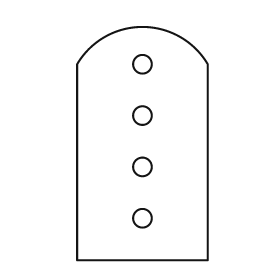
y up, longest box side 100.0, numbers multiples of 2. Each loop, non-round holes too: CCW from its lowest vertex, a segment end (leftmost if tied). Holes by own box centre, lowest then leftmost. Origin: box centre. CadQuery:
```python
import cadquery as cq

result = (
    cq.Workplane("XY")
    .moveTo(-28.0, -50.0)
    .lineTo(28.0, -50.0)
    .lineTo(28.0, 34.0)
    .threePointArc((0.0, 50.0), (-28.0, 34.0))
    .close()
    .moveTo(0.0, -32.0)
    .circle(4.0)
    .moveTo(0.0, -10.0)
    .circle(4.0)
    .moveTo(0.0, 12.0)
    .circle(4.0)
    .moveTo(0.0, 34.0)
    .circle(4.0)
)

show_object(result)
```